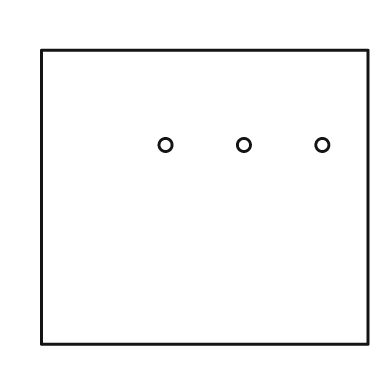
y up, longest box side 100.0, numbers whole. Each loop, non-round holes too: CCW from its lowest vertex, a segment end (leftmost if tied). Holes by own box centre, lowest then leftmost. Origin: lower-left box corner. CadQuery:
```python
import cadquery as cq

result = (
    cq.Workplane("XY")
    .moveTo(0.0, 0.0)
    .lineTo(100.0, 0.0)
    .lineTo(100.0, 90.0)
    .lineTo(0.0, 90.0)
    .close()
    .moveTo(38.0, 61.0)
    .circle(2.0)
    .moveTo(62.0, 61.0)
    .circle(2.0)
    .moveTo(86.0, 61.0)
    .circle(2.0)
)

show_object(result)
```